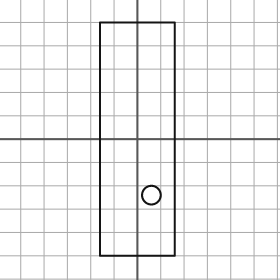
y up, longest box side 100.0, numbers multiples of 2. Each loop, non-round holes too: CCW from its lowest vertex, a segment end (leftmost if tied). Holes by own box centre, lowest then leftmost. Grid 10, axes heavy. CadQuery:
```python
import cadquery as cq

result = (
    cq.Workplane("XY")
    .moveTo(-16.0, -50.0)
    .lineTo(16.0, -50.0)
    .lineTo(16.0, 50.0)
    .lineTo(-16.0, 50.0)
    .close()
    .moveTo(6.0, -24.0)
    .circle(4.0)
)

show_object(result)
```